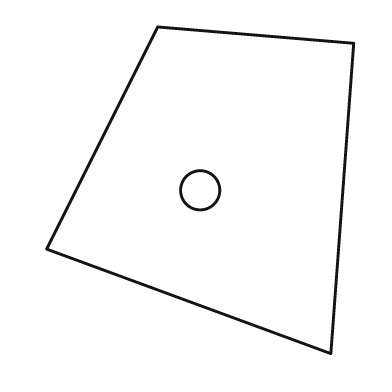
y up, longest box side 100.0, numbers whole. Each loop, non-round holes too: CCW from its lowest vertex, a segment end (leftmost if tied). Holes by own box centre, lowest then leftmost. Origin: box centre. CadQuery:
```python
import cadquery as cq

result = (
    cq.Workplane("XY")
    .moveTo(40.0, -50.0)
    .lineTo(47.0, 45.0)
    .lineTo(-13.0, 50.0)
    .lineTo(-47.0, -18.0)
    .close()
    .moveTo(0.0, 0.0)
    .circle(6.0)
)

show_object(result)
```